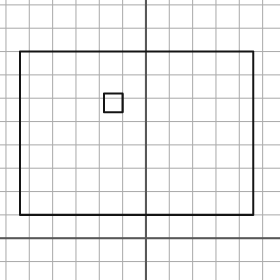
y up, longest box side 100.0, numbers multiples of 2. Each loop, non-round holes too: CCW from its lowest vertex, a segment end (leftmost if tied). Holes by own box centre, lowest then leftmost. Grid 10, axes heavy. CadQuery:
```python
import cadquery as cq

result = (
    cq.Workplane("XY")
    .moveTo(-54.0, 10.0)
    .lineTo(46.0, 10.0)
    .lineTo(46.0, 80.0)
    .lineTo(-54.0, 80.0)
    .close()
    .moveTo(-18.0, 54.0)
    .lineTo(-10.0, 54.0)
    .lineTo(-10.0, 62.0)
    .lineTo(-18.0, 62.0)
    .close()
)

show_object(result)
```